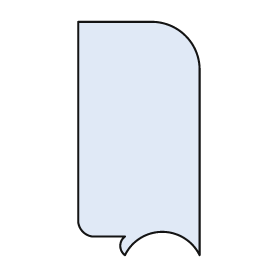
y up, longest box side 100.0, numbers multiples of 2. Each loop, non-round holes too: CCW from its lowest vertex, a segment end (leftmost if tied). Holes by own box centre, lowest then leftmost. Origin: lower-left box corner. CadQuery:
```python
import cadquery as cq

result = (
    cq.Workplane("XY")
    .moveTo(20.0, 0.0)
    .threePointArc((36.0, 10.0), (52.0, 0.0))
    .lineTo(52.0, 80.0)
    .threePointArc((46.0, 94.0), (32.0, 100.0))
    .lineTo(0.0, 100.0)
    .lineTo(0.0, 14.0)
    .threePointArc((2.0, 10.0), (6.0, 8.0))
    .lineTo(20.0, 8.0)
    .threePointArc((18.0, 4.0), (20.0, 0.0))
    .close()
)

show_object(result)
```